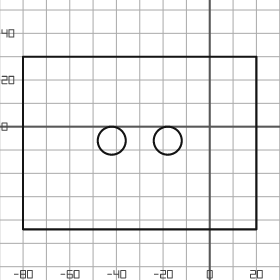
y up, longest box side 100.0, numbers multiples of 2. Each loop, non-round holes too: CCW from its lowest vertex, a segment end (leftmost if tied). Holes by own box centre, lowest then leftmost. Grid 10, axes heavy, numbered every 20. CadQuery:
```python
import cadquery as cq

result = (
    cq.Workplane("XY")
    .moveTo(-80.0, -44.0)
    .lineTo(20.0, -44.0)
    .lineTo(20.0, 30.0)
    .lineTo(-80.0, 30.0)
    .close()
    .moveTo(-42.0, -6.0)
    .circle(6.0)
    .moveTo(-18.0, -6.0)
    .circle(6.0)
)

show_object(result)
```